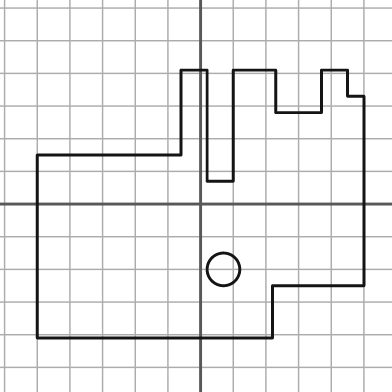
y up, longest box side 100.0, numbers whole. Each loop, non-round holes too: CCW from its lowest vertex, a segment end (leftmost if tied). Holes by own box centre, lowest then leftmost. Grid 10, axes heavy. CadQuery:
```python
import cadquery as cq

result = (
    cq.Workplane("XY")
    .moveTo(-50.0, -41.0)
    .lineTo(22.0, -41.0)
    .lineTo(22.0, -25.0)
    .lineTo(50.0, -25.0)
    .lineTo(50.0, 33.0)
    .lineTo(45.0, 33.0)
    .lineTo(45.0, 41.0)
    .lineTo(37.0, 41.0)
    .lineTo(37.0, 28.0)
    .lineTo(23.0, 28.0)
    .lineTo(23.0, 41.0)
    .lineTo(10.0, 41.0)
    .lineTo(10.0, 7.0)
    .lineTo(2.0, 7.0)
    .lineTo(2.0, 41.0)
    .lineTo(-6.0, 41.0)
    .lineTo(-6.0, 15.0)
    .lineTo(-50.0, 15.0)
    .close()
    .moveTo(7.0, -20.0)
    .circle(5.0)
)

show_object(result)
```